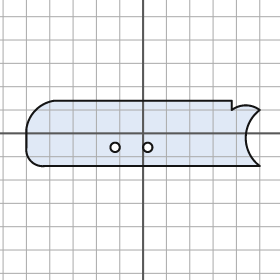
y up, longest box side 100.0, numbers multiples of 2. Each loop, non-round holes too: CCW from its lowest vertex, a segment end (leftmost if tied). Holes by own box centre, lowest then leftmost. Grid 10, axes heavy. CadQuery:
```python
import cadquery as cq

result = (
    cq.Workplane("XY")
    .moveTo(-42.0, -14.0)
    .lineTo(50.0, -14.0)
    .threePointArc((44.0, -2.0), (50.0, 10.0))
    .threePointArc((44.0, 12.0), (38.0, 10.0))
    .lineTo(38.0, 14.0)
    .lineTo(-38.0, 14.0)
    .threePointArc((-46.0, 10.0), (-50.0, 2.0))
    .lineTo(-50.0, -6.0)
    .threePointArc((-48.0, -12.0), (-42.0, -14.0))
    .close()
    .moveTo(-12.0, -6.0)
    .circle(2.0)
    .moveTo(2.0, -6.0)
    .circle(2.0)
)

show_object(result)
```